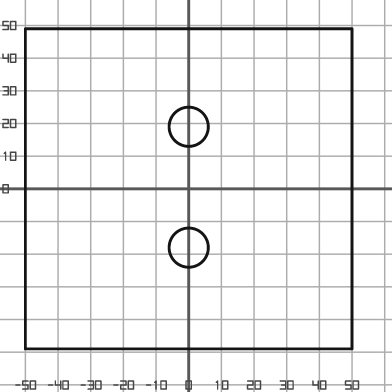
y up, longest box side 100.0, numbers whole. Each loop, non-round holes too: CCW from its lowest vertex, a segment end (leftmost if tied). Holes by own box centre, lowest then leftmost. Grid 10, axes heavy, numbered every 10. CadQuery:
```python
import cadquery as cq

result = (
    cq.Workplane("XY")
    .moveTo(-50.0, -49.0)
    .lineTo(50.0, -49.0)
    .lineTo(50.0, 49.0)
    .lineTo(-50.0, 49.0)
    .close()
    .moveTo(0.0, -18.0)
    .circle(6.0)
    .moveTo(0.0, 19.0)
    .circle(6.0)
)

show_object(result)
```